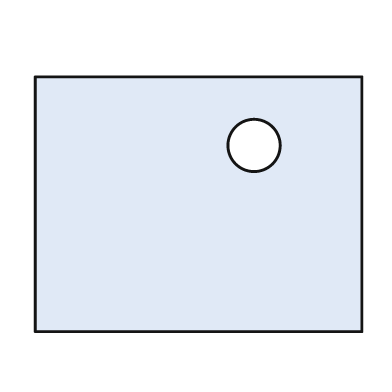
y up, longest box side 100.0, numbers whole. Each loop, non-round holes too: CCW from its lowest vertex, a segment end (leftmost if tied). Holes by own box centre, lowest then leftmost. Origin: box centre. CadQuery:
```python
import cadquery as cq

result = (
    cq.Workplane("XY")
    .moveTo(-50.0, -39.0)
    .lineTo(50.0, -39.0)
    .lineTo(50.0, 39.0)
    .lineTo(-50.0, 39.0)
    .close()
    .moveTo(17.0, 18.0)
    .circle(8.0)
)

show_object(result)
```